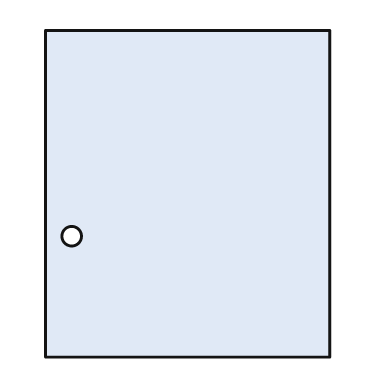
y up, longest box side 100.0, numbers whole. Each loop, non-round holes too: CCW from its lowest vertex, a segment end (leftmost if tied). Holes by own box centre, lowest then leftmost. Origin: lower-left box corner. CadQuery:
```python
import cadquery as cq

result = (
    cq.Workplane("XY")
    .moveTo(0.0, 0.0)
    .lineTo(87.0, 0.0)
    .lineTo(87.0, 100.0)
    .lineTo(0.0, 100.0)
    .close()
    .moveTo(8.0, 37.0)
    .circle(3.0)
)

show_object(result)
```